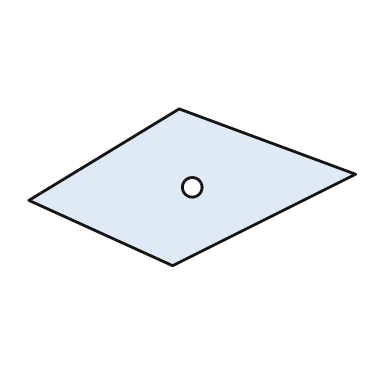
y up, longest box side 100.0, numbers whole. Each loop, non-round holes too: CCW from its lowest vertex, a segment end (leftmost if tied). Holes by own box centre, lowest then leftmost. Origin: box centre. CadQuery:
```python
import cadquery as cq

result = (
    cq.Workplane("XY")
    .moveTo(-6.0, -24.0)
    .lineTo(50.0, 4.0)
    .lineTo(-4.0, 24.0)
    .lineTo(-50.0, -4.0)
    .close()
    .moveTo(0.0, 0.0)
    .circle(3.0)
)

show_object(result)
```